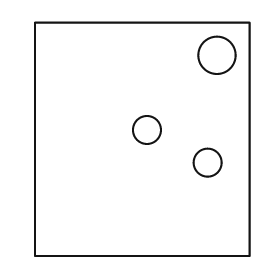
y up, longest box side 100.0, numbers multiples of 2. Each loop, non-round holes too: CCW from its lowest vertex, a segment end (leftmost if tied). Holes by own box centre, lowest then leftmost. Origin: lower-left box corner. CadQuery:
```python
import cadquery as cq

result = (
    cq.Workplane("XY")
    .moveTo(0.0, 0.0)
    .lineTo(92.0, 0.0)
    .lineTo(92.0, 100.0)
    .lineTo(0.0, 100.0)
    .close()
    .moveTo(74.0, 40.0)
    .circle(6.0)
    .moveTo(48.0, 54.0)
    .circle(6.0)
    .moveTo(78.0, 86.0)
    .circle(8.0)
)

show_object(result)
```